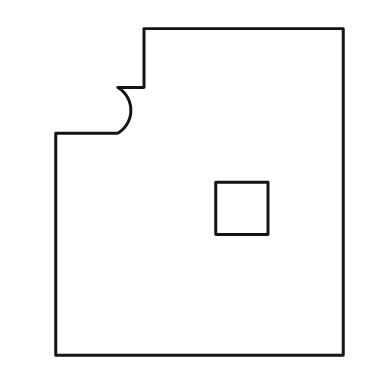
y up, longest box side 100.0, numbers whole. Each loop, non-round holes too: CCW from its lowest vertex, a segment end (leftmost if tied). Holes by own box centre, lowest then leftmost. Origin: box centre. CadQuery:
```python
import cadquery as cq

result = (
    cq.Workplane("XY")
    .moveTo(-44.0, -50.0)
    .lineTo(44.0, -50.0)
    .lineTo(44.0, 50.0)
    .lineTo(-17.0, 50.0)
    .lineTo(-17.0, 32.0)
    .lineTo(-25.0, 32.0)
    .threePointArc((-21.0, 25.0), (-25.0, 18.0))
    .lineTo(-44.0, 18.0)
    .close()
    .moveTo(5.0, -13.0)
    .lineTo(21.0, -13.0)
    .lineTo(21.0, 3.0)
    .lineTo(5.0, 3.0)
    .close()
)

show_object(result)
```